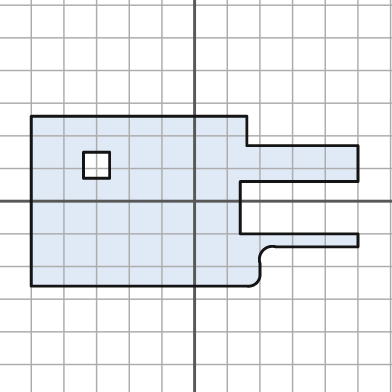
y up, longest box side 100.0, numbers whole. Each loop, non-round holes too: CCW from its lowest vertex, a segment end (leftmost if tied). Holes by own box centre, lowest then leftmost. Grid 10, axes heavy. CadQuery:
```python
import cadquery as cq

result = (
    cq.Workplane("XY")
    .moveTo(-50.0, -26.0)
    .lineTo(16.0, -26.0)
    .threePointArc((19.0, -25.0), (20.0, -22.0))
    .lineTo(20.0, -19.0)
    .threePointArc((21.0, -15.0), (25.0, -14.0))
    .lineTo(50.0, -14.0)
    .lineTo(50.0, -10.0)
    .lineTo(14.0, -10.0)
    .lineTo(14.0, 6.0)
    .lineTo(50.0, 6.0)
    .lineTo(50.0, 17.0)
    .lineTo(16.0, 17.0)
    .lineTo(16.0, 26.0)
    .lineTo(-50.0, 26.0)
    .close()
    .moveTo(-34.0, 7.0)
    .lineTo(-26.0, 7.0)
    .lineTo(-26.0, 15.0)
    .lineTo(-34.0, 15.0)
    .close()
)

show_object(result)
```